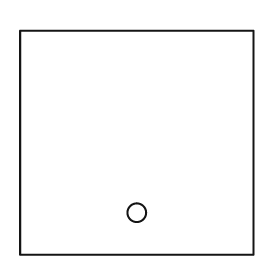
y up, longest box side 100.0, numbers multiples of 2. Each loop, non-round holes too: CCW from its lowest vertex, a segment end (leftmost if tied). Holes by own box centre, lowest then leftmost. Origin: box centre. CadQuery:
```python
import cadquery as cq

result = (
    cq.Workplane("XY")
    .moveTo(-50.0, -48.0)
    .lineTo(50.0, -48.0)
    .lineTo(50.0, 48.0)
    .lineTo(-50.0, 48.0)
    .close()
    .moveTo(0.0, -30.0)
    .circle(4.0)
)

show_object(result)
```